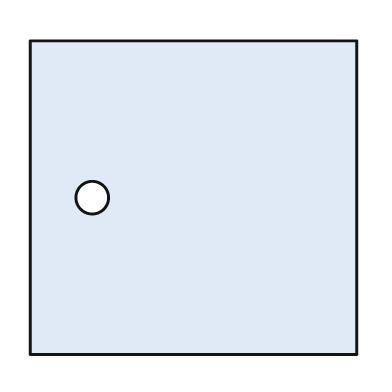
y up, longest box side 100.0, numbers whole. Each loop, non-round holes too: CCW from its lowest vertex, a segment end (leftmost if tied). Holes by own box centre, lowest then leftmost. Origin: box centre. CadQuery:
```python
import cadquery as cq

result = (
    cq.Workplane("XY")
    .moveTo(-50.0, -48.0)
    .lineTo(50.0, -48.0)
    .lineTo(50.0, 48.0)
    .lineTo(-50.0, 48.0)
    .close()
    .moveTo(-31.0, 0.0)
    .circle(5.0)
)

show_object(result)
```